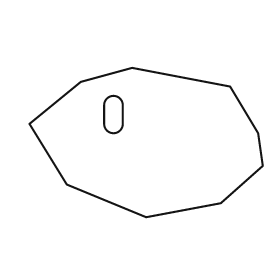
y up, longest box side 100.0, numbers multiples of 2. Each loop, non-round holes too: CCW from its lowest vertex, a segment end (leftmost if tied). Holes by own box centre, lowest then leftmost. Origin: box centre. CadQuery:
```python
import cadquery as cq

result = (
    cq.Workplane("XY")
    .moveTo(0.0, -32.0)
    .lineTo(32.0, -26.0)
    .lineTo(50.0, -10.0)
    .lineTo(48.0, 4.0)
    .lineTo(36.0, 24.0)
    .lineTo(-6.0, 32.0)
    .lineTo(-28.0, 26.0)
    .lineTo(-50.0, 8.0)
    .lineTo(-34.0, -18.0)
    .close()
    .moveTo(-18.0, 8.0)
    .threePointArc((-14.0, 4.0), (-10.0, 8.0))
    .lineTo(-10.0, 16.0)
    .threePointArc((-14.0, 20.0), (-18.0, 16.0))
    .close()
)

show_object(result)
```